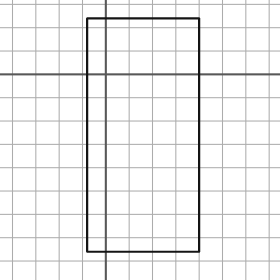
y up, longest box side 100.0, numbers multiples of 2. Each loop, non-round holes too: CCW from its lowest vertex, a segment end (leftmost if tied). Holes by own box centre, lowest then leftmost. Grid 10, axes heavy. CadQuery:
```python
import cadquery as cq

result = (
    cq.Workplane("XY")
    .moveTo(-8.0, -76.0)
    .lineTo(40.0, -76.0)
    .lineTo(40.0, 24.0)
    .lineTo(-8.0, 24.0)
    .close()
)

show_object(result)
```